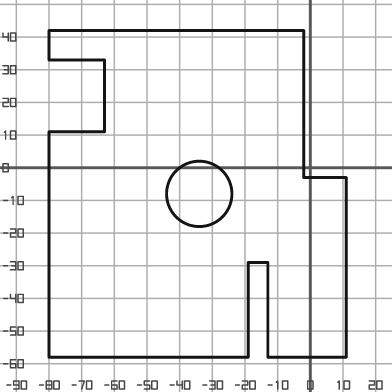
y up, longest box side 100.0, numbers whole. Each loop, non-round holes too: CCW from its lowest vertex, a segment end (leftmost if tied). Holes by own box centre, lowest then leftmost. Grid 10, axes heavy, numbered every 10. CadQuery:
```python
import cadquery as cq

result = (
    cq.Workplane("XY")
    .moveTo(-80.0, -58.0)
    .lineTo(-19.0, -58.0)
    .lineTo(-19.0, -29.0)
    .lineTo(-13.0, -29.0)
    .lineTo(-13.0, -58.0)
    .lineTo(11.0, -58.0)
    .lineTo(11.0, -3.0)
    .lineTo(-2.0, -3.0)
    .lineTo(-2.0, 42.0)
    .lineTo(-80.0, 42.0)
    .lineTo(-80.0, 33.0)
    .lineTo(-63.0, 33.0)
    .lineTo(-63.0, 11.0)
    .lineTo(-80.0, 11.0)
    .close()
    .moveTo(-34.0, -8.0)
    .circle(10.0)
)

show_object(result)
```